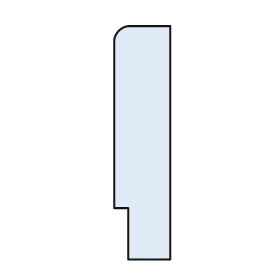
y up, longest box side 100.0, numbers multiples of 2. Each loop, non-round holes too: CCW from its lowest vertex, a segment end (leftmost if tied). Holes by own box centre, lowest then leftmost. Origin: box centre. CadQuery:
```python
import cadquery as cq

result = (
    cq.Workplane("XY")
    .moveTo(-6.0, -50.0)
    .lineTo(12.0, -50.0)
    .lineTo(12.0, 50.0)
    .lineTo(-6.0, 50.0)
    .threePointArc((-10.0, 48.0), (-12.0, 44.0))
    .lineTo(-12.0, -28.0)
    .lineTo(-6.0, -28.0)
    .close()
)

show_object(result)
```